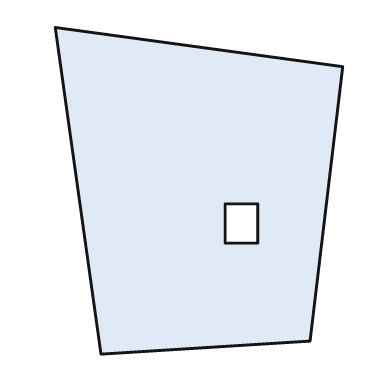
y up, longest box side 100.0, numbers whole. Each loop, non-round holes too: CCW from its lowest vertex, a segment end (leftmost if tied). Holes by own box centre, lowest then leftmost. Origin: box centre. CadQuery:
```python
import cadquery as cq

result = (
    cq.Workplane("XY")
    .moveTo(-30.0, -50.0)
    .lineTo(34.0, -46.0)
    .lineTo(44.0, 38.0)
    .lineTo(-44.0, 50.0)
    .close()
    .moveTo(8.0, -16.0)
    .lineTo(18.0, -16.0)
    .lineTo(18.0, -4.0)
    .lineTo(8.0, -4.0)
    .close()
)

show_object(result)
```